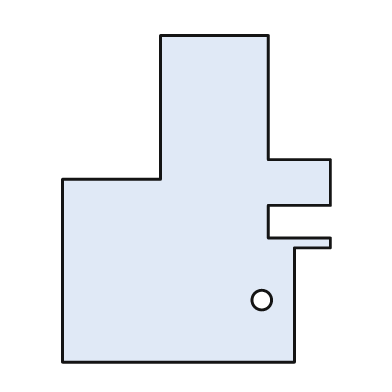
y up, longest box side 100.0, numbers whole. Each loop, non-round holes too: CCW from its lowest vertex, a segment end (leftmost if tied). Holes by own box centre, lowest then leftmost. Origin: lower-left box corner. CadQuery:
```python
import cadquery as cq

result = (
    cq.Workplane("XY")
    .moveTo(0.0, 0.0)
    .lineTo(71.0, 0.0)
    .lineTo(71.0, 35.0)
    .lineTo(82.0, 35.0)
    .lineTo(82.0, 38.0)
    .lineTo(63.0, 38.0)
    .lineTo(63.0, 48.0)
    .lineTo(82.0, 48.0)
    .lineTo(82.0, 62.0)
    .lineTo(63.0, 62.0)
    .lineTo(63.0, 100.0)
    .lineTo(30.0, 100.0)
    .lineTo(30.0, 56.0)
    .lineTo(0.0, 56.0)
    .close()
    .moveTo(61.0, 19.0)
    .circle(3.0)
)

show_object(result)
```